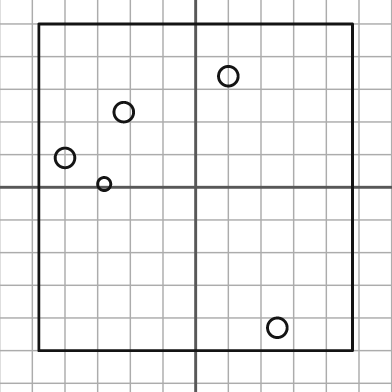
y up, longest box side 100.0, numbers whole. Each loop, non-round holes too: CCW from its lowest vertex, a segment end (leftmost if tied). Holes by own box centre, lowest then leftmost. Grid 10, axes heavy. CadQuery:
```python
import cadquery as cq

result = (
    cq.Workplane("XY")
    .moveTo(-48.0, -50.0)
    .lineTo(48.0, -50.0)
    .lineTo(48.0, 50.0)
    .lineTo(-48.0, 50.0)
    .close()
    .moveTo(25.0, -43.0)
    .circle(3.0)
    .moveTo(-28.0, 1.0)
    .circle(2.0)
    .moveTo(-40.0, 9.0)
    .circle(3.0)
    .moveTo(-22.0, 23.0)
    .circle(3.0)
    .moveTo(10.0, 34.0)
    .circle(3.0)
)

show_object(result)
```